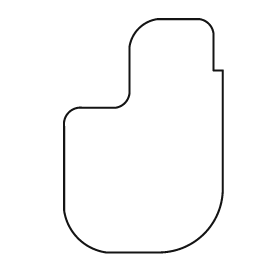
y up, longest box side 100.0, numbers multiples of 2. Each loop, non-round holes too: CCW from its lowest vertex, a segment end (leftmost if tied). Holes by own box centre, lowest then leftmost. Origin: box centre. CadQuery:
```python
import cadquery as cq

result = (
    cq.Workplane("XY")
    .moveTo(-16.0, -50.0)
    .lineTo(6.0, -50.0)
    .threePointArc((26.0, -42.0), (34.0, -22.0))
    .lineTo(34.0, 28.0)
    .lineTo(30.0, 28.0)
    .lineTo(30.0, 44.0)
    .threePointArc((28.0, 48.0), (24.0, 50.0))
    .lineTo(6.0, 50.0)
    .threePointArc((-2.0, 46.0), (-6.0, 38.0))
    .lineTo(-6.0, 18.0)
    .threePointArc((-8.0, 14.0), (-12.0, 12.0))
    .lineTo(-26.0, 12.0)
    .threePointArc((-32.0, 10.0), (-34.0, 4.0))
    .lineTo(-34.0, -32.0)
    .threePointArc((-28.0, -44.0), (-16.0, -50.0))
    .close()
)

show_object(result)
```